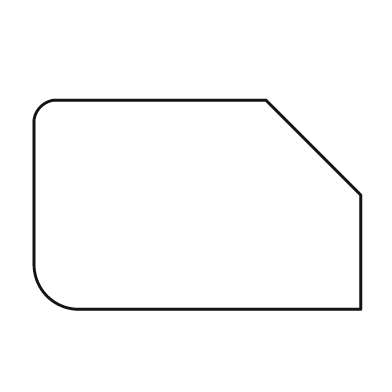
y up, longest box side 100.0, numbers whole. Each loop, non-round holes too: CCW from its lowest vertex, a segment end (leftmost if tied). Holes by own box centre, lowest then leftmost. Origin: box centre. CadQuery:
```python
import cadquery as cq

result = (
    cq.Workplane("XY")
    .moveTo(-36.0, -32.0)
    .lineTo(50.0, -32.0)
    .lineTo(50.0, 3.0)
    .lineTo(21.0, 32.0)
    .lineTo(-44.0, 32.0)
    .threePointArc((-48.0, 30.0), (-50.0, 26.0))
    .lineTo(-50.0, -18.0)
    .threePointArc((-46.0, -28.0), (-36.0, -32.0))
    .close()
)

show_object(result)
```